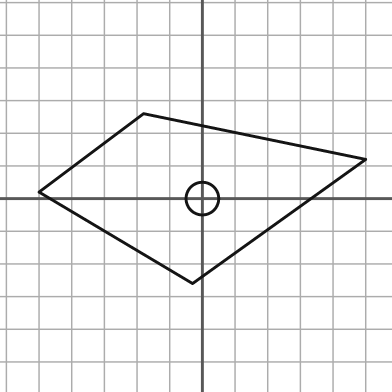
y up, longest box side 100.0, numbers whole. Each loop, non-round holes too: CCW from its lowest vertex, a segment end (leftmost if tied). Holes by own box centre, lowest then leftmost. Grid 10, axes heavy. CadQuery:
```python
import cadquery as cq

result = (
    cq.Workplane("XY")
    .moveTo(-3.0, -26.0)
    .lineTo(50.0, 12.0)
    .lineTo(-18.0, 26.0)
    .lineTo(-50.0, 2.0)
    .close()
    .moveTo(0.0, 0.0)
    .circle(5.0)
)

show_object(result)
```